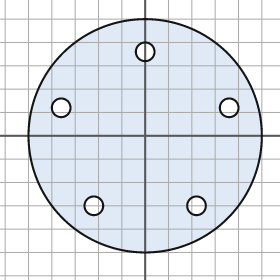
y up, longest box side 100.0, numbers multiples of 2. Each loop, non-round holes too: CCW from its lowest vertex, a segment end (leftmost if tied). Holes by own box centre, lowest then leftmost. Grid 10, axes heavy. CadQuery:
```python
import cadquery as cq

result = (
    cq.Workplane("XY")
    .moveTo(0.0, 0.0)
    .circle(50.0)
    .moveTo(-22.0, -30.0)
    .circle(4.0)
    .moveTo(22.0, -30.0)
    .circle(4.0)
    .moveTo(-36.0, 12.0)
    .circle(4.0)
    .moveTo(36.0, 12.0)
    .circle(4.0)
    .moveTo(0.0, 36.0)
    .circle(4.0)
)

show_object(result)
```